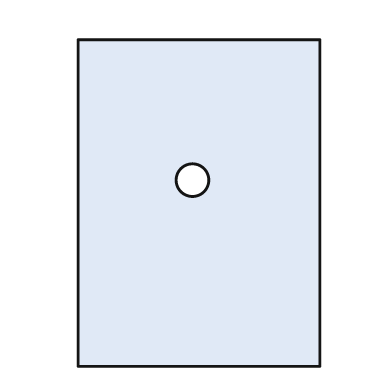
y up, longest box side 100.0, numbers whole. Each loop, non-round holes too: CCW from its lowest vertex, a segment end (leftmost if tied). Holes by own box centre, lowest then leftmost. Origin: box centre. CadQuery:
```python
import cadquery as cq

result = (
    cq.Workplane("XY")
    .moveTo(-37.0, -50.0)
    .lineTo(37.0, -50.0)
    .lineTo(37.0, 50.0)
    .lineTo(-37.0, 50.0)
    .close()
    .moveTo(-2.0, 7.0)
    .circle(5.0)
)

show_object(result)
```